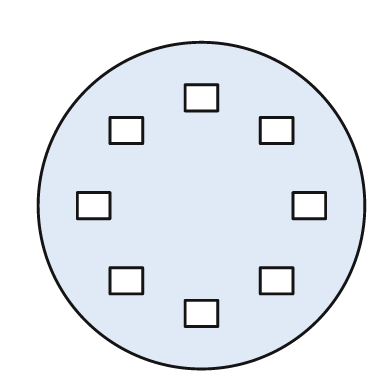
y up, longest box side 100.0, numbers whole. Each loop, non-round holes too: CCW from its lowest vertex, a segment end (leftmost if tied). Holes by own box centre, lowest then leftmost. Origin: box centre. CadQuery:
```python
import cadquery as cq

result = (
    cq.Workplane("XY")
    .moveTo(0.0, 0.0)
    .circle(50.0)
    .moveTo(-5.0, -37.0)
    .lineTo(5.0, -37.0)
    .lineTo(5.0, -29.0)
    .lineTo(-5.0, -29.0)
    .close()
    .moveTo(-28.0, -27.0)
    .lineTo(-18.0, -27.0)
    .lineTo(-18.0, -19.0)
    .lineTo(-28.0, -19.0)
    .close()
    .moveTo(18.0, -27.0)
    .lineTo(28.0, -27.0)
    .lineTo(28.0, -19.0)
    .lineTo(18.0, -19.0)
    .close()
    .moveTo(-38.0, -4.0)
    .lineTo(-28.0, -4.0)
    .lineTo(-28.0, 4.0)
    .lineTo(-38.0, 4.0)
    .close()
    .moveTo(28.0, -4.0)
    .lineTo(38.0, -4.0)
    .lineTo(38.0, 4.0)
    .lineTo(28.0, 4.0)
    .close()
    .moveTo(-28.0, 19.0)
    .lineTo(-18.0, 19.0)
    .lineTo(-18.0, 27.0)
    .lineTo(-28.0, 27.0)
    .close()
    .moveTo(18.0, 19.0)
    .lineTo(28.0, 19.0)
    .lineTo(28.0, 27.0)
    .lineTo(18.0, 27.0)
    .close()
    .moveTo(-5.0, 29.0)
    .lineTo(5.0, 29.0)
    .lineTo(5.0, 37.0)
    .lineTo(-5.0, 37.0)
    .close()
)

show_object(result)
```